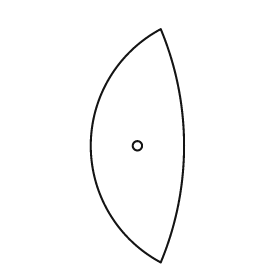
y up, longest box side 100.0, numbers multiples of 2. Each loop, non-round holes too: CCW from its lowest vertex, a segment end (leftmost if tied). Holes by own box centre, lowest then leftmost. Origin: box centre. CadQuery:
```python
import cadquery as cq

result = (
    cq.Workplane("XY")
    .moveTo(10.0, -50.0)
    .threePointArc((20.0, 0.0), (10.0, 50.0))
    .threePointArc((-20.0, 0.0), (10.0, -50.0))
    .close()
    .moveTo(0.0, 0.0)
    .circle(2.0)
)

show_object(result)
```